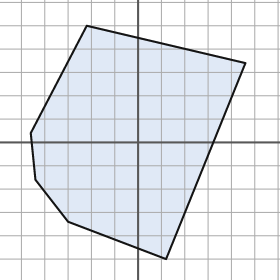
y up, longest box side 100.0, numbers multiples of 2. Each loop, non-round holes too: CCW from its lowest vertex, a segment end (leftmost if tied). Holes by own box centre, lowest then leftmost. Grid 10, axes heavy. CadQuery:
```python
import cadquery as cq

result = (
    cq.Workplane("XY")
    .moveTo(12.0, -50.0)
    .lineTo(46.0, 34.0)
    .lineTo(-22.0, 50.0)
    .lineTo(-46.0, 4.0)
    .lineTo(-44.0, -16.0)
    .lineTo(-30.0, -34.0)
    .close()
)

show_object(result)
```